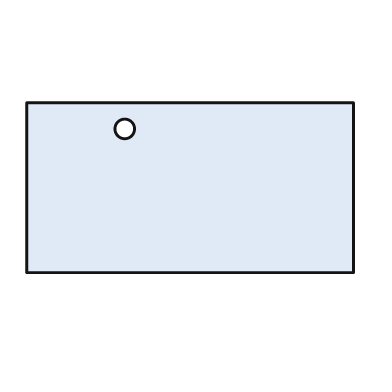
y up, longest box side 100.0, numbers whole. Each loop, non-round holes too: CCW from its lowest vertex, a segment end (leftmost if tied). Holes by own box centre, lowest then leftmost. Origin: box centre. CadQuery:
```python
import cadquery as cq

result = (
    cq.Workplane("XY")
    .moveTo(-50.0, -26.0)
    .lineTo(50.0, -26.0)
    .lineTo(50.0, 26.0)
    .lineTo(-50.0, 26.0)
    .close()
    .moveTo(-20.0, 18.0)
    .circle(3.0)
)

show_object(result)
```